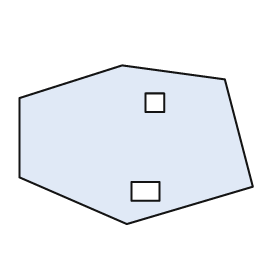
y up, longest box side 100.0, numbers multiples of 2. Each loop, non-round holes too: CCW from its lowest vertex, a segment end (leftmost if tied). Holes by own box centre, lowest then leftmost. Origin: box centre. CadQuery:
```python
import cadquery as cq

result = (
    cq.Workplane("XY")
    .moveTo(-4.0, -34.0)
    .lineTo(50.0, -18.0)
    .lineTo(38.0, 28.0)
    .lineTo(-6.0, 34.0)
    .lineTo(-50.0, 20.0)
    .lineTo(-50.0, -14.0)
    .close()
    .moveTo(-2.0, -24.0)
    .lineTo(10.0, -24.0)
    .lineTo(10.0, -16.0)
    .lineTo(-2.0, -16.0)
    .close()
    .moveTo(4.0, 14.0)
    .lineTo(12.0, 14.0)
    .lineTo(12.0, 22.0)
    .lineTo(4.0, 22.0)
    .close()
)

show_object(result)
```